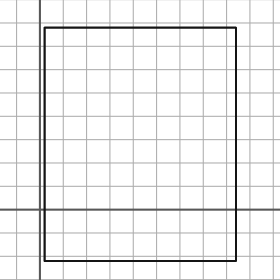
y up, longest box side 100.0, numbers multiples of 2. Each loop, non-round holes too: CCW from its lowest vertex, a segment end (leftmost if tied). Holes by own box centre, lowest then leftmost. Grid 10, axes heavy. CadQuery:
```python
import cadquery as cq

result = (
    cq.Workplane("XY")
    .moveTo(2.0, -22.0)
    .lineTo(84.0, -22.0)
    .lineTo(84.0, 78.0)
    .lineTo(2.0, 78.0)
    .close()
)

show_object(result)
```